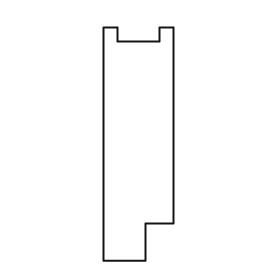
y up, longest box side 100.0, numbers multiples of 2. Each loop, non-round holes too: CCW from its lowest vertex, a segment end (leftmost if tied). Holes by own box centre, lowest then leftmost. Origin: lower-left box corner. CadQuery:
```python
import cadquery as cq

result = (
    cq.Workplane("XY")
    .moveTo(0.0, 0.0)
    .lineTo(18.0, 0.0)
    .lineTo(18.0, 16.0)
    .lineTo(30.0, 16.0)
    .lineTo(30.0, 100.0)
    .lineTo(24.0, 100.0)
    .lineTo(24.0, 94.0)
    .lineTo(6.0, 94.0)
    .lineTo(6.0, 100.0)
    .lineTo(0.0, 100.0)
    .close()
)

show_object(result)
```